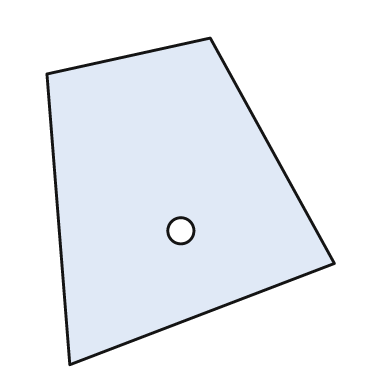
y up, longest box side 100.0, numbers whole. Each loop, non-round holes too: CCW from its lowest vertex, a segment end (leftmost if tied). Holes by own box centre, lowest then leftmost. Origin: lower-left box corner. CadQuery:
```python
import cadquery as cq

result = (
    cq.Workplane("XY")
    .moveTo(7.0, 0.0)
    .lineTo(88.0, 31.0)
    .lineTo(50.0, 100.0)
    .lineTo(0.0, 89.0)
    .close()
    .moveTo(41.0, 41.0)
    .circle(4.0)
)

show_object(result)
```